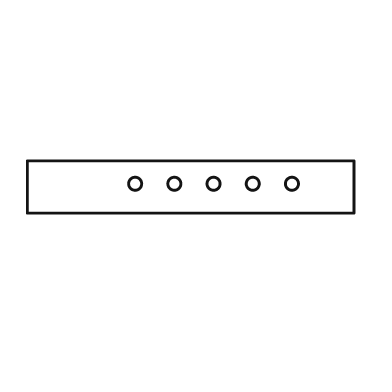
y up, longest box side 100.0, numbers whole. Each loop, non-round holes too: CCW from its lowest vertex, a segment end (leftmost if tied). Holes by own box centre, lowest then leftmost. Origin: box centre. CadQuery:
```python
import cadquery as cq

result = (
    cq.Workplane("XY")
    .moveTo(-50.0, -8.0)
    .lineTo(50.0, -8.0)
    .lineTo(50.0, 8.0)
    .lineTo(-50.0, 8.0)
    .close()
    .moveTo(-17.0, 1.0)
    .circle(2.0)
    .moveTo(-5.0, 1.0)
    .circle(2.0)
    .moveTo(7.0, 1.0)
    .circle(2.0)
    .moveTo(19.0, 1.0)
    .circle(2.0)
    .moveTo(31.0, 1.0)
    .circle(2.0)
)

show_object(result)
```